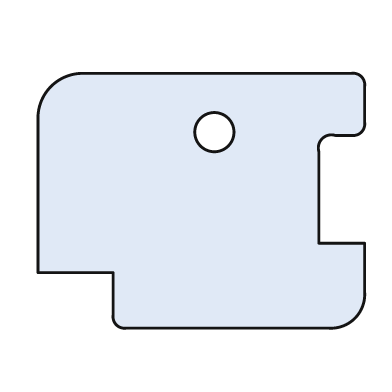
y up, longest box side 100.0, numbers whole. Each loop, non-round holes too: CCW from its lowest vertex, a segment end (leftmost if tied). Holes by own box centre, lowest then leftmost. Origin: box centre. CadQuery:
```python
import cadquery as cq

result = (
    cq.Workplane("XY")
    .moveTo(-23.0, -39.0)
    .lineTo(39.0, -39.0)
    .threePointArc((47.0, -36.0), (50.0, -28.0))
    .lineTo(50.0, -13.0)
    .lineTo(36.0, -13.0)
    .lineTo(36.0, 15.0)
    .threePointArc((37.0, 19.0), (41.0, 20.0))
    .lineTo(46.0, 20.0)
    .threePointArc((49.0, 21.0), (50.0, 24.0))
    .lineTo(50.0, 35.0)
    .threePointArc((49.0, 38.0), (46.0, 39.0))
    .lineTo(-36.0, 39.0)
    .threePointArc((-46.0, 35.0), (-50.0, 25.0))
    .lineTo(-50.0, -22.0)
    .lineTo(-27.0, -22.0)
    .lineTo(-27.0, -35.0)
    .threePointArc((-26.0, -38.0), (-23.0, -39.0))
    .close()
    .moveTo(4.0, 21.0)
    .circle(6.0)
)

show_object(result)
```